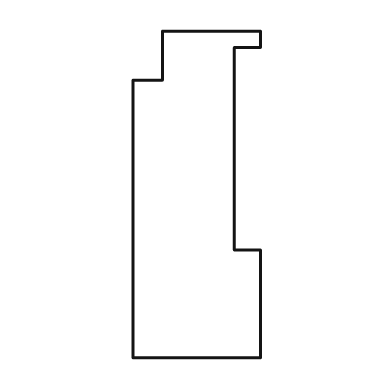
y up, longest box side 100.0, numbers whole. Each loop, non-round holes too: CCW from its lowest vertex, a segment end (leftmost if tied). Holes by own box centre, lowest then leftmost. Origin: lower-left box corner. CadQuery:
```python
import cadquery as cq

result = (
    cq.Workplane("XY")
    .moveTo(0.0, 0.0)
    .lineTo(39.0, 0.0)
    .lineTo(39.0, 33.0)
    .lineTo(31.0, 33.0)
    .lineTo(31.0, 95.0)
    .lineTo(39.0, 95.0)
    .lineTo(39.0, 100.0)
    .lineTo(9.0, 100.0)
    .lineTo(9.0, 85.0)
    .lineTo(0.0, 85.0)
    .close()
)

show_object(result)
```